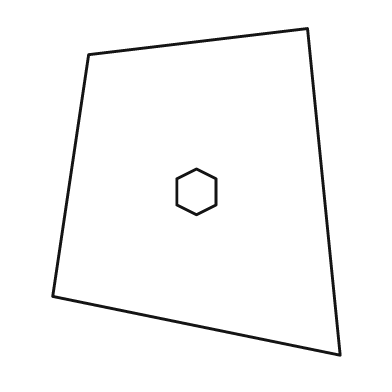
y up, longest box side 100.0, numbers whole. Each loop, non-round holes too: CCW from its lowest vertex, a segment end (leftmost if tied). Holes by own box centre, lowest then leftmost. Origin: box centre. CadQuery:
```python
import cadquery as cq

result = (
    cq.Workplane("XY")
    .moveTo(44.0, -50.0)
    .lineTo(34.0, 50.0)
    .lineTo(-33.0, 42.0)
    .lineTo(-44.0, -32.0)
    .close()
    .moveTo(0.0, -7.0)
    .lineTo(6.0, -4.0)
    .lineTo(6.0, 4.0)
    .lineTo(0.0, 7.0)
    .lineTo(-6.0, 4.0)
    .lineTo(-6.0, -4.0)
    .close()
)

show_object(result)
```